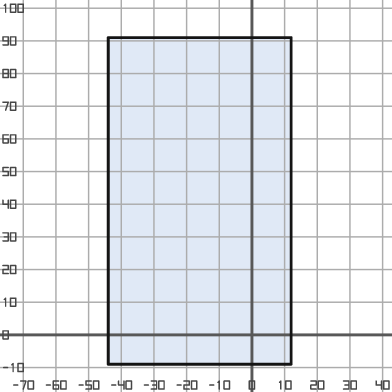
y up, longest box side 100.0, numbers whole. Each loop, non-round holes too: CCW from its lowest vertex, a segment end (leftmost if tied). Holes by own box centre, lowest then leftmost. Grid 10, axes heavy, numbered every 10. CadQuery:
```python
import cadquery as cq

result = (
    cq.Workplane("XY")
    .moveTo(-44.0, -9.0)
    .lineTo(12.0, -9.0)
    .lineTo(12.0, 91.0)
    .lineTo(-44.0, 91.0)
    .close()
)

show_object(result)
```